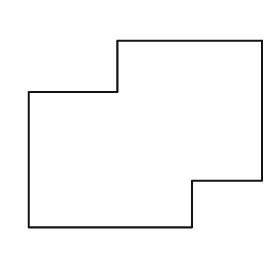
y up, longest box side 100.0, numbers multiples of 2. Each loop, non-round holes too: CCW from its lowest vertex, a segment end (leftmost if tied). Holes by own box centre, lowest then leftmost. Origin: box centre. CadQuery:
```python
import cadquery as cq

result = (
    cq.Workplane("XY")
    .moveTo(-50.0, -40.0)
    .lineTo(20.0, -40.0)
    .lineTo(20.0, -20.0)
    .lineTo(50.0, -20.0)
    .lineTo(50.0, 40.0)
    .lineTo(-12.0, 40.0)
    .lineTo(-12.0, 18.0)
    .lineTo(-50.0, 18.0)
    .close()
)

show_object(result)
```